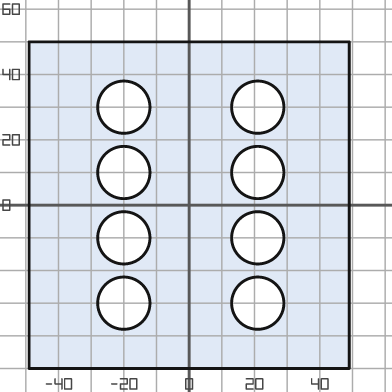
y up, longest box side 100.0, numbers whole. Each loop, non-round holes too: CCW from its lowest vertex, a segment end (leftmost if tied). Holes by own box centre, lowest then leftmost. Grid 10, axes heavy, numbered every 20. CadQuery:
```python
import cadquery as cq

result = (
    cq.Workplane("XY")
    .moveTo(-49.0, -50.0)
    .lineTo(49.0, -50.0)
    .lineTo(49.0, 50.0)
    .lineTo(-49.0, 50.0)
    .close()
    .moveTo(-20.0, -30.0)
    .circle(8.0)
    .moveTo(21.0, -30.0)
    .circle(8.0)
    .moveTo(-20.0, -10.0)
    .circle(8.0)
    .moveTo(21.0, -10.0)
    .circle(8.0)
    .moveTo(-20.0, 10.0)
    .circle(8.0)
    .moveTo(21.0, 10.0)
    .circle(8.0)
    .moveTo(-20.0, 30.0)
    .circle(8.0)
    .moveTo(21.0, 30.0)
    .circle(8.0)
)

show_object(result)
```